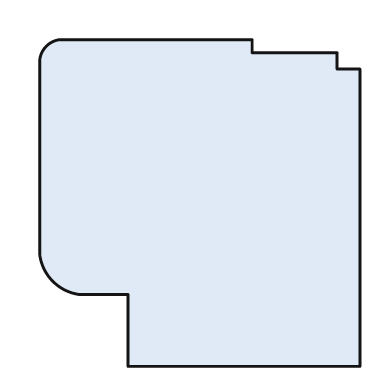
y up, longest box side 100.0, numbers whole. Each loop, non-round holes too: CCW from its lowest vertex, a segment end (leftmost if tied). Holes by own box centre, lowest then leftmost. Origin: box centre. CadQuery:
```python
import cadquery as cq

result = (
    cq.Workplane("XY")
    .moveTo(-22.0, -50.0)
    .lineTo(49.0, -50.0)
    .lineTo(49.0, 41.0)
    .lineTo(42.0, 41.0)
    .lineTo(42.0, 46.0)
    .lineTo(16.0, 46.0)
    .lineTo(16.0, 50.0)
    .lineTo(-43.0, 50.0)
    .threePointArc((-47.0, 48.0), (-49.0, 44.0))
    .lineTo(-49.0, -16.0)
    .threePointArc((-45.0, -24.0), (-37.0, -28.0))
    .lineTo(-22.0, -28.0)
    .close()
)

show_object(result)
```